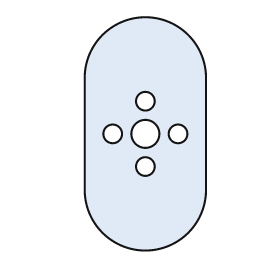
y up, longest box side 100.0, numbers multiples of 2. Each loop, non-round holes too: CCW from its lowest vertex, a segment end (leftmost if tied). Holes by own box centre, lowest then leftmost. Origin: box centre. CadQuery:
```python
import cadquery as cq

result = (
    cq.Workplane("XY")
    .moveTo(-26.0, -24.0)
    .threePointArc((0.0, -50.0), (26.0, -24.0))
    .lineTo(26.0, 24.0)
    .threePointArc((0.0, 50.0), (-26.0, 24.0))
    .close()
    .moveTo(0.0, -14.0)
    .circle(4.0)
    .moveTo(-14.0, 0.0)
    .circle(4.0)
    .moveTo(0.0, 0.0)
    .circle(6.0)
    .moveTo(14.0, 0.0)
    .circle(4.0)
    .moveTo(0.0, 14.0)
    .circle(4.0)
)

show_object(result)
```